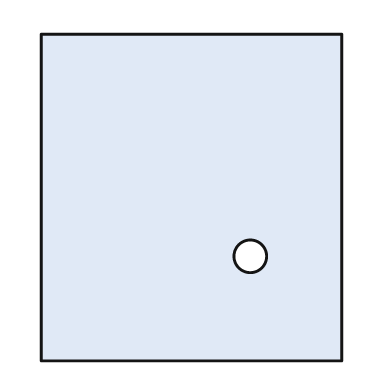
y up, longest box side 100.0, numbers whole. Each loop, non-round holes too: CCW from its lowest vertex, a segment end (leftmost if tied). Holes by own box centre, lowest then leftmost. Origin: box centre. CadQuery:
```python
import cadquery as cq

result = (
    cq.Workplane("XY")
    .moveTo(-46.0, -50.0)
    .lineTo(46.0, -50.0)
    .lineTo(46.0, 50.0)
    .lineTo(-46.0, 50.0)
    .close()
    .moveTo(18.0, -18.0)
    .circle(5.0)
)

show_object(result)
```